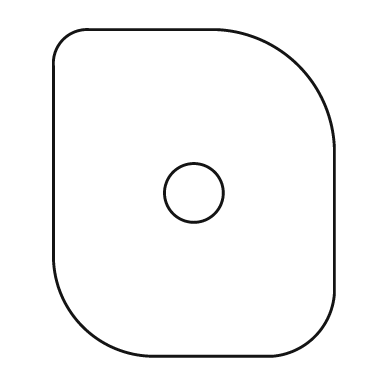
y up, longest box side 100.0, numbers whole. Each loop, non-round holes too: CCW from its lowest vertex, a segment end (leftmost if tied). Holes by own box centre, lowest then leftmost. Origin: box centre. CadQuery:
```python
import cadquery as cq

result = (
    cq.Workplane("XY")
    .moveTo(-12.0, -50.0)
    .lineTo(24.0, -50.0)
    .threePointArc((37.0, -44.0), (43.0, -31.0))
    .lineTo(43.0, 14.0)
    .threePointArc((32.0, 39.0), (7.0, 50.0))
    .lineTo(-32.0, 50.0)
    .threePointArc((-40.0, 47.0), (-43.0, 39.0))
    .lineTo(-43.0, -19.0)
    .threePointArc((-34.0, -41.0), (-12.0, -50.0))
    .close()
    .moveTo(0.0, 0.0)
    .circle(9.0)
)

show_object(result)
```